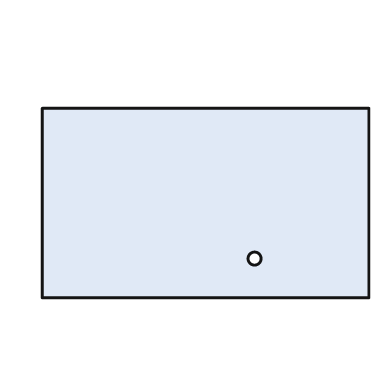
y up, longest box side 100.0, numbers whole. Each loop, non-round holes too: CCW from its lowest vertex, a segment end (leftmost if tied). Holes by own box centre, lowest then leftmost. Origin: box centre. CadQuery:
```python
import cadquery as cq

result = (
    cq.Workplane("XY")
    .moveTo(-50.0, -29.0)
    .lineTo(50.0, -29.0)
    .lineTo(50.0, 29.0)
    .lineTo(-50.0, 29.0)
    .close()
    .moveTo(15.0, -17.0)
    .circle(2.0)
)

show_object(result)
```